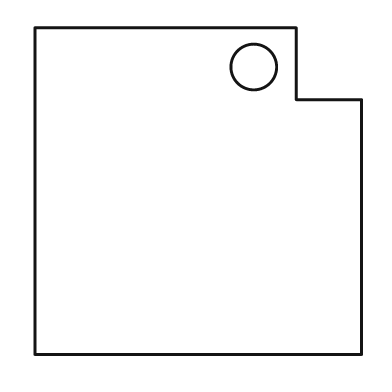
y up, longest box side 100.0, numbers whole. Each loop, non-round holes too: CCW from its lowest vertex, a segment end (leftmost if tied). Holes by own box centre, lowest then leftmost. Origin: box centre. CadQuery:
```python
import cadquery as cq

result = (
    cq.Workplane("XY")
    .moveTo(-50.0, -50.0)
    .lineTo(50.0, -50.0)
    .lineTo(50.0, 28.0)
    .lineTo(30.0, 28.0)
    .lineTo(30.0, 50.0)
    .lineTo(-50.0, 50.0)
    .close()
    .moveTo(17.0, 38.0)
    .circle(7.0)
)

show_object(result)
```